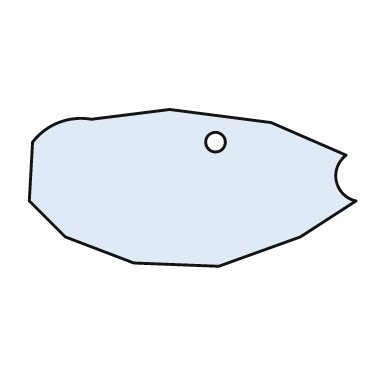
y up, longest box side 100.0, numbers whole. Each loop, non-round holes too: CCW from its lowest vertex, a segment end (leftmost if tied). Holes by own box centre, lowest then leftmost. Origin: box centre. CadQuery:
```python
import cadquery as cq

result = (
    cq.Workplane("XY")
    .moveTo(8.0, -24.0)
    .lineTo(33.0, -15.0)
    .lineTo(50.0, -4.0)
    .threePointArc((44.0, 2.0), (47.0, 10.0))
    .lineTo(24.0, 20.0)
    .lineTo(-7.0, 24.0)
    .lineTo(-31.0, 21.0)
    .threePointArc((-41.0, 20.0), (-49.0, 14.0))
    .lineTo(-50.0, -4.0)
    .lineTo(-39.0, -15.0)
    .lineTo(-18.0, -23.0)
    .close()
    .moveTo(7.0, 14.0)
    .circle(3.0)
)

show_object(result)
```